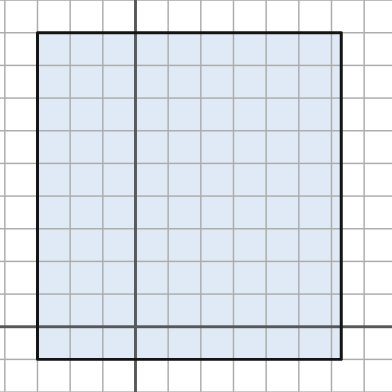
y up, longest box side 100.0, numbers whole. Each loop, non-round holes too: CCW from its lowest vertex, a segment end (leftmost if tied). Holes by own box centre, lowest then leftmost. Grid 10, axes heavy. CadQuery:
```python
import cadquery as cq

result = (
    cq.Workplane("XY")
    .moveTo(-30.0, -10.0)
    .lineTo(63.0, -10.0)
    .lineTo(63.0, 90.0)
    .lineTo(-30.0, 90.0)
    .close()
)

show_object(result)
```